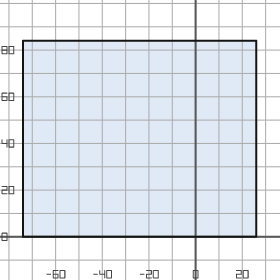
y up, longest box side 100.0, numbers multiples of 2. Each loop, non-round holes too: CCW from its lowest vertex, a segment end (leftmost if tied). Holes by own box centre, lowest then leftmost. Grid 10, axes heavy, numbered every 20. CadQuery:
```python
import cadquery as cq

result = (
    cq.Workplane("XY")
    .moveTo(-74.0, 0.0)
    .lineTo(26.0, 0.0)
    .lineTo(26.0, 84.0)
    .lineTo(-74.0, 84.0)
    .close()
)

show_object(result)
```